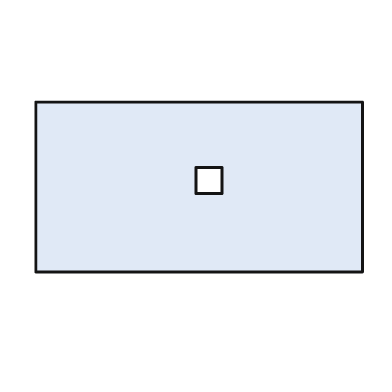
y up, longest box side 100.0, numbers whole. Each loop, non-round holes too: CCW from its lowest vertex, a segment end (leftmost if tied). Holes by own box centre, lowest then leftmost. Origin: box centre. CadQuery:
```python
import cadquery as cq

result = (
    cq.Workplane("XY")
    .moveTo(-50.0, -26.0)
    .lineTo(50.0, -26.0)
    .lineTo(50.0, 26.0)
    .lineTo(-50.0, 26.0)
    .close()
    .moveTo(-1.0, -2.0)
    .lineTo(7.0, -2.0)
    .lineTo(7.0, 6.0)
    .lineTo(-1.0, 6.0)
    .close()
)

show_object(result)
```